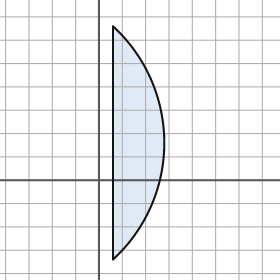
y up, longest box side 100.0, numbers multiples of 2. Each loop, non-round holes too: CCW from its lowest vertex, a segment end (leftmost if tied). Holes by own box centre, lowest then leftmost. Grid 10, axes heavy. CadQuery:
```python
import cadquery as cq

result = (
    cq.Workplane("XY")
    .moveTo(6.0, -34.0)
    .threePointArc((28.0, 16.0), (6.0, 66.0))
    .close()
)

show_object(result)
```